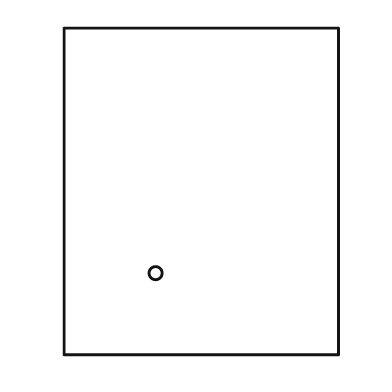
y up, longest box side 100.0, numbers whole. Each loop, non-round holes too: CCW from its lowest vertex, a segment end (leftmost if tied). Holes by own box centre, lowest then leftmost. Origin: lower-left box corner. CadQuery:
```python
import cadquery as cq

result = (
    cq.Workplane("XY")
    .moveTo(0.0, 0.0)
    .lineTo(84.0, 0.0)
    .lineTo(84.0, 100.0)
    .lineTo(0.0, 100.0)
    .close()
    .moveTo(28.0, 25.0)
    .circle(2.0)
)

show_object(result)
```